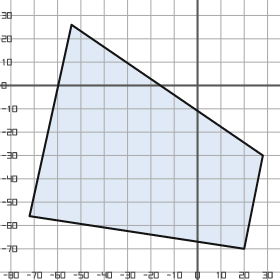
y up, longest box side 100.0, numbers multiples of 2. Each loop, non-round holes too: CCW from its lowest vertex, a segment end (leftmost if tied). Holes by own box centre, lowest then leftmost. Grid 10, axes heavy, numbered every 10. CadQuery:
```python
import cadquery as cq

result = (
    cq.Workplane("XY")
    .moveTo(20.0, -70.0)
    .lineTo(28.0, -30.0)
    .lineTo(-54.0, 26.0)
    .lineTo(-72.0, -56.0)
    .close()
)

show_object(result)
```